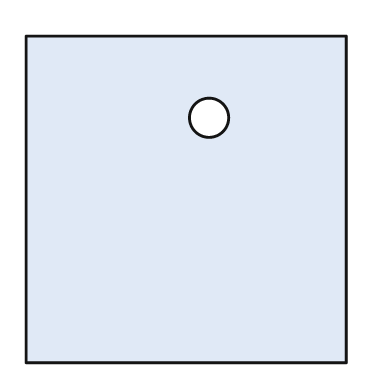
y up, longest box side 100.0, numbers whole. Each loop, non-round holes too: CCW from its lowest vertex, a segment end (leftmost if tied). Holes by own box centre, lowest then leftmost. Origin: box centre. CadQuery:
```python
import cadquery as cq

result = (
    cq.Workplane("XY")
    .moveTo(-49.0, -50.0)
    .lineTo(49.0, -50.0)
    .lineTo(49.0, 50.0)
    .lineTo(-49.0, 50.0)
    .close()
    .moveTo(7.0, 25.0)
    .circle(6.0)
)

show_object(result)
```